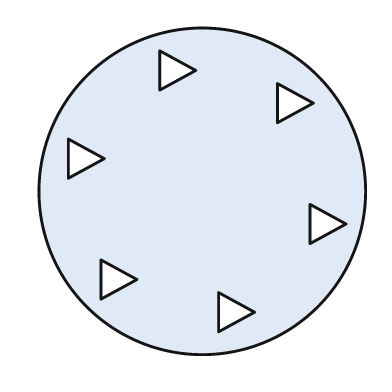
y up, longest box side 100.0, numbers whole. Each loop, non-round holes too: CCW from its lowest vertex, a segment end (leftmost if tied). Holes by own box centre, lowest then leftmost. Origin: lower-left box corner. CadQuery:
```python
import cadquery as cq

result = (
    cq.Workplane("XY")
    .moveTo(50.0, 50.0)
    .circle(50.0)
    .moveTo(55.0, 7.0)
    .lineTo(66.0, 13.0)
    .lineTo(55.0, 19.0)
    .close()
    .moveTo(19.0, 17.0)
    .lineTo(30.0, 23.0)
    .lineTo(19.0, 29.0)
    .close()
    .moveTo(83.0, 34.0)
    .lineTo(94.0, 40.0)
    .lineTo(83.0, 46.0)
    .close()
    .moveTo(9.0, 54.0)
    .lineTo(20.0, 60.0)
    .lineTo(9.0, 66.0)
    .close()
    .moveTo(73.0, 71.0)
    .lineTo(84.0, 77.0)
    .lineTo(73.0, 83.0)
    .close()
    .moveTo(37.0, 81.0)
    .lineTo(48.0, 87.0)
    .lineTo(37.0, 93.0)
    .close()
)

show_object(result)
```